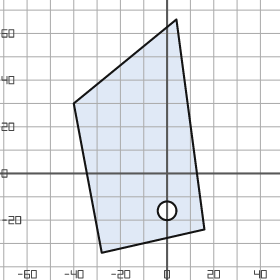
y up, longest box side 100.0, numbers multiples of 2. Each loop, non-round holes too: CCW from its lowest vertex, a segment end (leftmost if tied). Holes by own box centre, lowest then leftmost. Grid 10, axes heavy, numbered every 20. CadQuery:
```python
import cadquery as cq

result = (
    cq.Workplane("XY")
    .moveTo(-28.0, -34.0)
    .lineTo(16.0, -24.0)
    .lineTo(4.0, 66.0)
    .lineTo(-40.0, 30.0)
    .close()
    .moveTo(0.0, -16.0)
    .circle(4.0)
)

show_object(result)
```